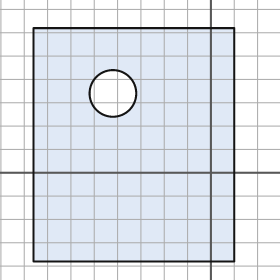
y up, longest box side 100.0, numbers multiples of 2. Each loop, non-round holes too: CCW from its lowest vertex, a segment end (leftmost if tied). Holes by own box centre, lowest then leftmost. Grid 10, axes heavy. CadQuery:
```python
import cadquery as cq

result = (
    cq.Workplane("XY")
    .moveTo(-76.0, -38.0)
    .lineTo(10.0, -38.0)
    .lineTo(10.0, 62.0)
    .lineTo(-76.0, 62.0)
    .close()
    .moveTo(-42.0, 34.0)
    .circle(10.0)
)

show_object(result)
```